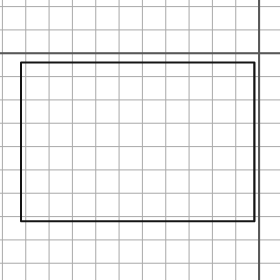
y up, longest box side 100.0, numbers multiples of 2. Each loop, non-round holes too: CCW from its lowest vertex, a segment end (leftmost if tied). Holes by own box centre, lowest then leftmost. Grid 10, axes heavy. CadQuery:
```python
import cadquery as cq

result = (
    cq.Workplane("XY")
    .moveTo(-102.0, -72.0)
    .lineTo(-2.0, -72.0)
    .lineTo(-2.0, -4.0)
    .lineTo(-102.0, -4.0)
    .close()
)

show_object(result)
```